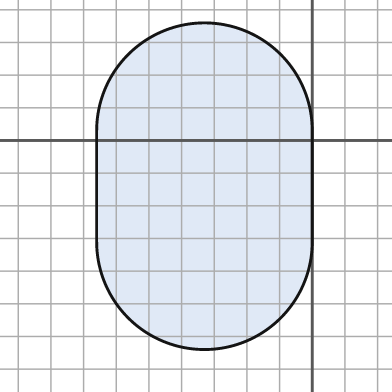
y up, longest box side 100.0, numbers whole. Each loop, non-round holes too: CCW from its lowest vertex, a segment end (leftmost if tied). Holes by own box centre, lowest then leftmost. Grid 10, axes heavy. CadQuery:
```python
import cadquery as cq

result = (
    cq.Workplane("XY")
    .moveTo(-66.0, -31.0)
    .threePointArc((-33.0, -64.0), (0.0, -31.0))
    .lineTo(0.0, 3.0)
    .threePointArc((-33.0, 36.0), (-66.0, 3.0))
    .close()
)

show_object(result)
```